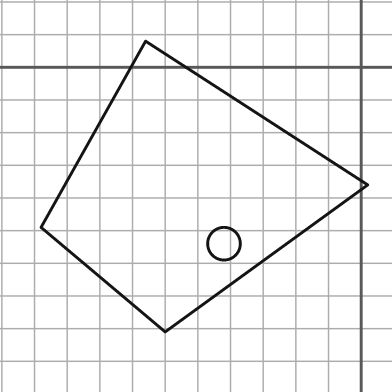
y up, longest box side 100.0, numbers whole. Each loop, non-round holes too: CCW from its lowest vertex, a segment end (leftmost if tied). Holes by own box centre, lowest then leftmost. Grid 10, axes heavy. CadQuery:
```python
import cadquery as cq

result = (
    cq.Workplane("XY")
    .moveTo(-60.0, -81.0)
    .lineTo(2.0, -36.0)
    .lineTo(-66.0, 8.0)
    .lineTo(-98.0, -49.0)
    .close()
    .moveTo(-42.0, -54.0)
    .circle(5.0)
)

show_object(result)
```